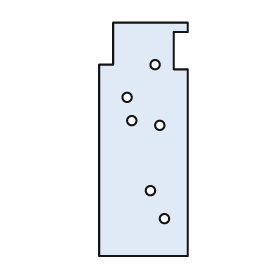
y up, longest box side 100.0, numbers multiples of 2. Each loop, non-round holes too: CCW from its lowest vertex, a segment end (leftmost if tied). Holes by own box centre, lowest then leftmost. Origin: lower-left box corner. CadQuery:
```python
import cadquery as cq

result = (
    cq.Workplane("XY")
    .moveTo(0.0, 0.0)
    .lineTo(38.0, 0.0)
    .lineTo(38.0, 80.0)
    .lineTo(32.0, 80.0)
    .lineTo(32.0, 96.0)
    .lineTo(38.0, 96.0)
    .lineTo(38.0, 100.0)
    .lineTo(6.0, 100.0)
    .lineTo(6.0, 82.0)
    .lineTo(0.0, 82.0)
    .close()
    .moveTo(28.0, 16.0)
    .circle(2.0)
    .moveTo(22.0, 28.0)
    .circle(2.0)
    .moveTo(26.0, 56.0)
    .circle(2.0)
    .moveTo(14.0, 58.0)
    .circle(2.0)
    .moveTo(12.0, 68.0)
    .circle(2.0)
    .moveTo(24.0, 82.0)
    .circle(2.0)
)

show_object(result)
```